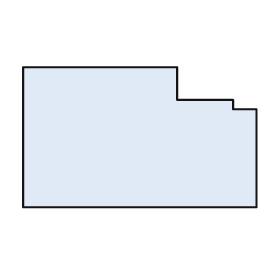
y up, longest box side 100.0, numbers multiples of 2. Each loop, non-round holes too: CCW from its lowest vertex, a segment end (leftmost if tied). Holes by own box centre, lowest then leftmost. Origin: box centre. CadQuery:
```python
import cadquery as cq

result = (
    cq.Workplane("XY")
    .moveTo(-50.0, -30.0)
    .lineTo(50.0, -30.0)
    .lineTo(50.0, 12.0)
    .lineTo(40.0, 12.0)
    .lineTo(40.0, 16.0)
    .lineTo(16.0, 16.0)
    .lineTo(16.0, 30.0)
    .lineTo(-50.0, 30.0)
    .close()
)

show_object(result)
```